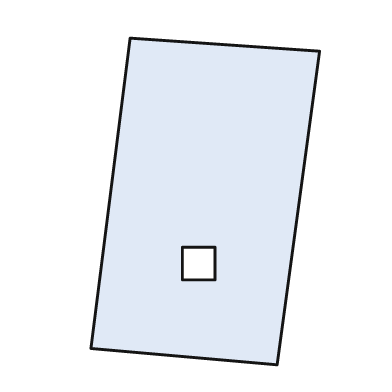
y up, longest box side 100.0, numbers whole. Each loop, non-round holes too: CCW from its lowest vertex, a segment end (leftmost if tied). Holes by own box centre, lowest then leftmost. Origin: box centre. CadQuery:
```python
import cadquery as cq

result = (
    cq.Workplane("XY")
    .moveTo(22.0, -50.0)
    .lineTo(35.0, 46.0)
    .lineTo(-23.0, 50.0)
    .lineTo(-35.0, -45.0)
    .close()
    .moveTo(-7.0, -24.0)
    .lineTo(3.0, -24.0)
    .lineTo(3.0, -14.0)
    .lineTo(-7.0, -14.0)
    .close()
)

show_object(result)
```